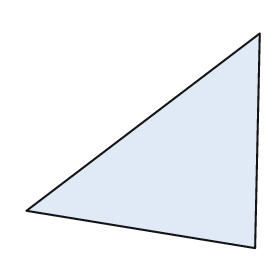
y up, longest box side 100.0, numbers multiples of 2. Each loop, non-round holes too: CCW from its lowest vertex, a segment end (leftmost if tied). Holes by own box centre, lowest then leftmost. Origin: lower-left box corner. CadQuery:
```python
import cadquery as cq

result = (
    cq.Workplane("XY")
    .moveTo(98.0, 0.0)
    .lineTo(100.0, 92.0)
    .lineTo(0.0, 16.0)
    .close()
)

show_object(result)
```